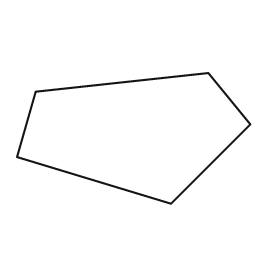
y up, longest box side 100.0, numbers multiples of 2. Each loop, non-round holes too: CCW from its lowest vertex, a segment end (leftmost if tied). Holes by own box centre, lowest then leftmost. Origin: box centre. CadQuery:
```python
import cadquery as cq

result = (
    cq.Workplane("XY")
    .moveTo(16.0, -28.0)
    .lineTo(50.0, 6.0)
    .lineTo(32.0, 28.0)
    .lineTo(-42.0, 20.0)
    .lineTo(-50.0, -8.0)
    .close()
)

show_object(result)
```